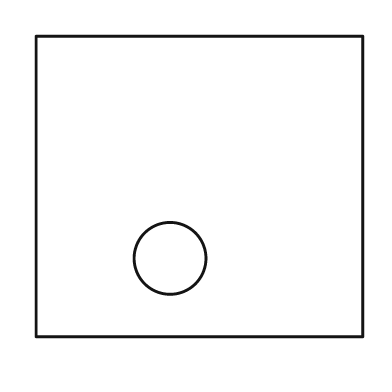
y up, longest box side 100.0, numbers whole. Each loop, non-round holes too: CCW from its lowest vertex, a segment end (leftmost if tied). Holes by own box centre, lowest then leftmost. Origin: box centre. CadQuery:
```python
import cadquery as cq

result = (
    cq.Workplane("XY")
    .moveTo(-50.0, -46.0)
    .lineTo(50.0, -46.0)
    .lineTo(50.0, 46.0)
    .lineTo(-50.0, 46.0)
    .close()
    .moveTo(-9.0, -22.0)
    .circle(11.0)
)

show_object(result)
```